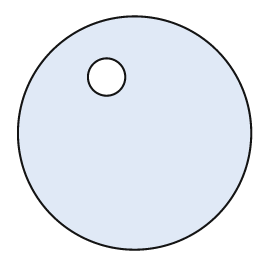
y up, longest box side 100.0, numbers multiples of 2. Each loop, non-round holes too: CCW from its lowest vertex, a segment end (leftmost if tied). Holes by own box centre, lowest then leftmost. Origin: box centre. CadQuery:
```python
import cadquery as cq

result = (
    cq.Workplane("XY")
    .moveTo(0.0, 0.0)
    .circle(50.0)
    .moveTo(-12.0, 24.0)
    .circle(8.0)
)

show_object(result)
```